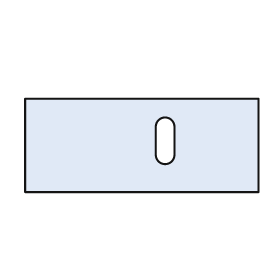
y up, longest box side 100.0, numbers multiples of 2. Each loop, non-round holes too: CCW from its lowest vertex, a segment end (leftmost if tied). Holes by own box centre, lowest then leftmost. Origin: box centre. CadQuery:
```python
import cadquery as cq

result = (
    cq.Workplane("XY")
    .moveTo(-50.0, -20.0)
    .lineTo(50.0, -20.0)
    .lineTo(50.0, 20.0)
    .lineTo(-50.0, 20.0)
    .close()
    .moveTo(6.0, -4.0)
    .threePointArc((10.0, -8.0), (14.0, -4.0))
    .lineTo(14.0, 8.0)
    .threePointArc((10.0, 12.0), (6.0, 8.0))
    .close()
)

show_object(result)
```